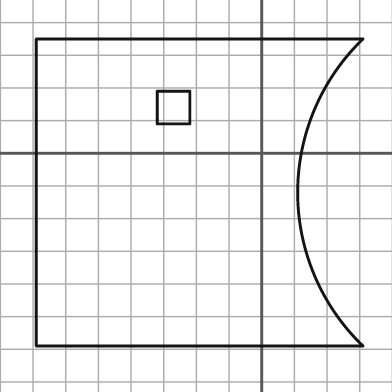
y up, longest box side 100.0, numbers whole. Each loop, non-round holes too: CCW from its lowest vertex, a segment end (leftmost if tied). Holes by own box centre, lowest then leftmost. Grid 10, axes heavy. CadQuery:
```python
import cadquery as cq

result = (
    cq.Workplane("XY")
    .moveTo(-69.0, -59.0)
    .lineTo(31.0, -59.0)
    .threePointArc((11.0, -12.0), (31.0, 35.0))
    .lineTo(-69.0, 35.0)
    .close()
    .moveTo(-32.0, 9.0)
    .lineTo(-22.0, 9.0)
    .lineTo(-22.0, 19.0)
    .lineTo(-32.0, 19.0)
    .close()
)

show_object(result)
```